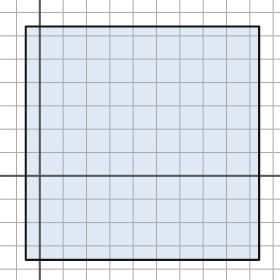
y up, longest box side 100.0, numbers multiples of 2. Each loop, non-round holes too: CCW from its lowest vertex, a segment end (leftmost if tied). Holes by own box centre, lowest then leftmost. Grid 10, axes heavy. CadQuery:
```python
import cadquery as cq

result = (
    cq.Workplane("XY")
    .moveTo(-6.0, -36.0)
    .lineTo(94.0, -36.0)
    .lineTo(94.0, 64.0)
    .lineTo(-6.0, 64.0)
    .close()
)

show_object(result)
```